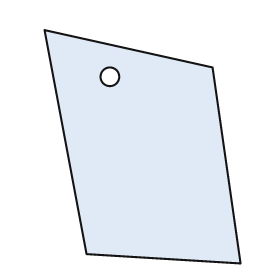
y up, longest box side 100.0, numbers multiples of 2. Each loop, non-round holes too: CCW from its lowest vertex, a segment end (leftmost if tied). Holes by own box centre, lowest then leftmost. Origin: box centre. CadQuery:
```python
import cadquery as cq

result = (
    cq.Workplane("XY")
    .moveTo(42.0, -50.0)
    .lineTo(30.0, 34.0)
    .lineTo(-42.0, 50.0)
    .lineTo(-24.0, -46.0)
    .close()
    .moveTo(-14.0, 30.0)
    .circle(4.0)
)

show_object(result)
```